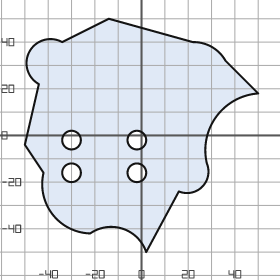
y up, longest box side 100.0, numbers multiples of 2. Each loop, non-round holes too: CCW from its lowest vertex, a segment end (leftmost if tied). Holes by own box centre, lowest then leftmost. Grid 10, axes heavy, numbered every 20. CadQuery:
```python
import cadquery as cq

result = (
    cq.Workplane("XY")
    .moveTo(2.0, -50.0)
    .lineTo(16.0, -24.0)
    .threePointArc((26.0, -22.0), (28.0, -12.0))
    .threePointArc((32.0, 8.0), (50.0, 18.0))
    .lineTo(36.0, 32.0)
    .threePointArc((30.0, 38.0), (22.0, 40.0))
    .lineTo(-14.0, 50.0)
    .lineTo(-34.0, 40.0)
    .threePointArc((-48.0, 36.0), (-44.0, 22.0))
    .lineTo(-50.0, -4.0)
    .lineTo(-42.0, -16.0)
    .threePointArc((-38.0, -34.0), (-22.0, -42.0))
    .threePointArc((-8.0, -40.0), (2.0, -50.0))
    .close()
    .moveTo(-30.0, -16.0)
    .circle(4.0)
    .moveTo(-2.0, -16.0)
    .circle(4.0)
    .moveTo(-30.0, -2.0)
    .circle(4.0)
    .moveTo(-2.0, -2.0)
    .circle(4.0)
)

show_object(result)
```